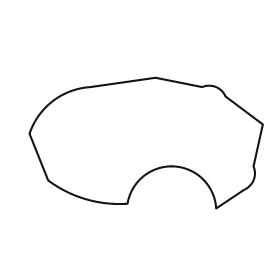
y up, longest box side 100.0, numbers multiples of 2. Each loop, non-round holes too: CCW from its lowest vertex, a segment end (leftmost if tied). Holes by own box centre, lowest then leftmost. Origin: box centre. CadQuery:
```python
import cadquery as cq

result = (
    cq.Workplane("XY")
    .moveTo(30.0, -28.0)
    .lineTo(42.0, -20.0)
    .threePointArc((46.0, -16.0), (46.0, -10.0))
    .lineTo(50.0, 8.0)
    .lineTo(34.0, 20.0)
    .threePointArc((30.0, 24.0), (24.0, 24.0))
    .lineTo(4.0, 28.0)
    .lineTo(-24.0, 24.0)
    .threePointArc((-40.0, 18.0), (-50.0, 4.0))
    .lineTo(-42.0, -16.0)
    .threePointArc((-26.0, -24.0), (-8.0, -26.0))
    .threePointArc((12.0, -10.0), (30.0, -28.0))
    .close()
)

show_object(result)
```